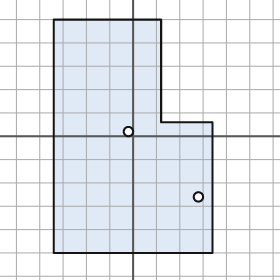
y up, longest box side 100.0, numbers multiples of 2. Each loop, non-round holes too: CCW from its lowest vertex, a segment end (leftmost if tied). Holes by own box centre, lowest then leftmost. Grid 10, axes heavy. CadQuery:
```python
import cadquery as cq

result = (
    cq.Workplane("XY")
    .moveTo(-34.0, -50.0)
    .lineTo(34.0, -50.0)
    .lineTo(34.0, 6.0)
    .lineTo(12.0, 6.0)
    .lineTo(12.0, 50.0)
    .lineTo(-34.0, 50.0)
    .close()
    .moveTo(28.0, -26.0)
    .circle(2.0)
    .moveTo(-2.0, 2.0)
    .circle(2.0)
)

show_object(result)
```